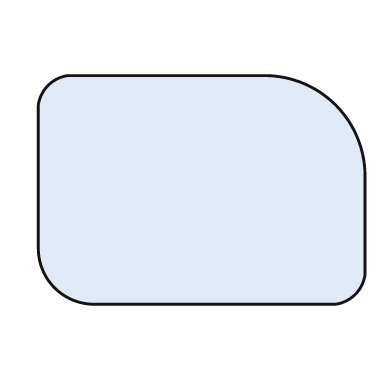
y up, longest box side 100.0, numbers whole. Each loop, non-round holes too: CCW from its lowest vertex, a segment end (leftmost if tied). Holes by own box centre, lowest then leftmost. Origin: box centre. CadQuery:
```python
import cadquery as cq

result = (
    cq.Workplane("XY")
    .moveTo(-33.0, -35.0)
    .lineTo(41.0, -35.0)
    .threePointArc((47.0, -32.0), (50.0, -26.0))
    .lineTo(50.0, 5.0)
    .threePointArc((41.0, 26.0), (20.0, 35.0))
    .lineTo(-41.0, 35.0)
    .threePointArc((-47.0, 32.0), (-50.0, 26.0))
    .lineTo(-50.0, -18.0)
    .threePointArc((-45.0, -30.0), (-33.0, -35.0))
    .close()
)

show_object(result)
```